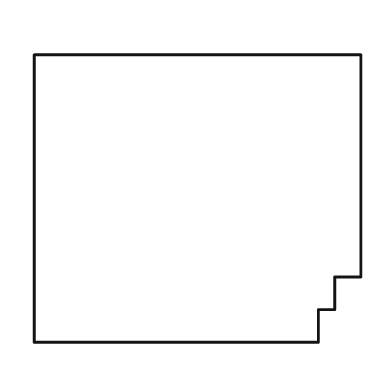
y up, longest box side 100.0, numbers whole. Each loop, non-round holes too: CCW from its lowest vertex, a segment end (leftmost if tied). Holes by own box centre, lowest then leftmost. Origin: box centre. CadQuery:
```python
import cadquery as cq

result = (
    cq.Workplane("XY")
    .moveTo(-50.0, -44.0)
    .lineTo(37.0, -44.0)
    .lineTo(37.0, -34.0)
    .lineTo(42.0, -34.0)
    .lineTo(42.0, -24.0)
    .lineTo(50.0, -24.0)
    .lineTo(50.0, 44.0)
    .lineTo(-50.0, 44.0)
    .close()
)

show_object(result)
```